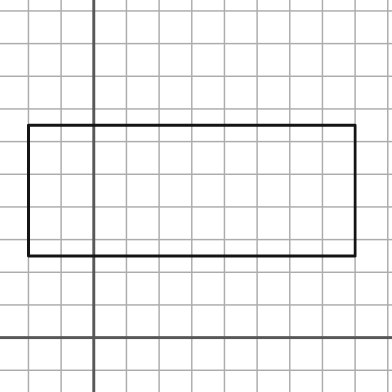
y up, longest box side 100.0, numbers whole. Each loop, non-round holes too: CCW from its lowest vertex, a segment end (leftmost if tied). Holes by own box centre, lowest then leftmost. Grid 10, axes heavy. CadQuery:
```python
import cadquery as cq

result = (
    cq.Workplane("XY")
    .moveTo(-20.0, 25.0)
    .lineTo(80.0, 25.0)
    .lineTo(80.0, 65.0)
    .lineTo(-20.0, 65.0)
    .close()
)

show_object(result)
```